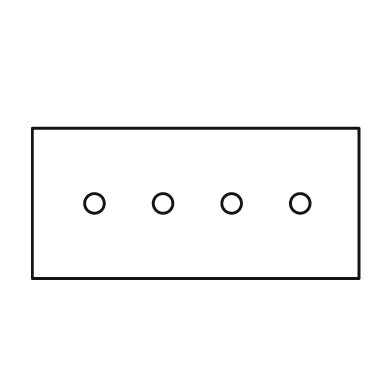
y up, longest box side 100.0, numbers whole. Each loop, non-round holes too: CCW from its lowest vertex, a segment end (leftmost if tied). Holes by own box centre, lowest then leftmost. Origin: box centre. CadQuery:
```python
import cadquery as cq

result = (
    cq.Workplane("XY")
    .moveTo(-50.0, -23.0)
    .lineTo(50.0, -23.0)
    .lineTo(50.0, 23.0)
    .lineTo(-50.0, 23.0)
    .close()
    .moveTo(-31.0, 0.0)
    .circle(3.0)
    .moveTo(-10.0, 0.0)
    .circle(3.0)
    .moveTo(11.0, 0.0)
    .circle(3.0)
    .moveTo(32.0, 0.0)
    .circle(3.0)
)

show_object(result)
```